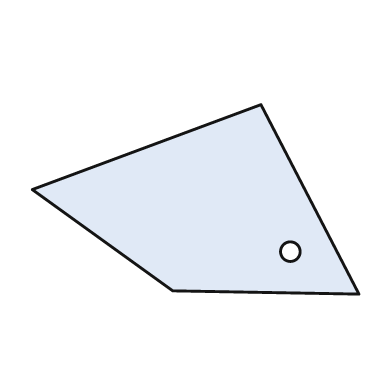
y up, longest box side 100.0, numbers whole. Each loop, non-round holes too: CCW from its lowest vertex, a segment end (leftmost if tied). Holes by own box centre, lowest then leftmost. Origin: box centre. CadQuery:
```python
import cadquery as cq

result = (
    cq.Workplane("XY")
    .moveTo(50.0, -29.0)
    .lineTo(20.0, 29.0)
    .lineTo(-50.0, 3.0)
    .lineTo(-7.0, -28.0)
    .close()
    .moveTo(29.0, -16.0)
    .circle(3.0)
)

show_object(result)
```